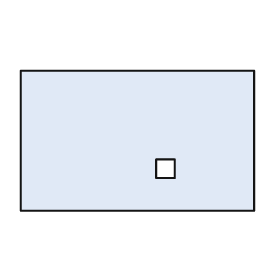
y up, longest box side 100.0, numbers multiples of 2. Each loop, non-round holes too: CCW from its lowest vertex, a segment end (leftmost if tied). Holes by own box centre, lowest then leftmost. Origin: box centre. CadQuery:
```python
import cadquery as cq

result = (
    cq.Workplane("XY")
    .moveTo(-50.0, -30.0)
    .lineTo(50.0, -30.0)
    .lineTo(50.0, 30.0)
    .lineTo(-50.0, 30.0)
    .close()
    .moveTo(8.0, -16.0)
    .lineTo(16.0, -16.0)
    .lineTo(16.0, -8.0)
    .lineTo(8.0, -8.0)
    .close()
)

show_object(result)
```